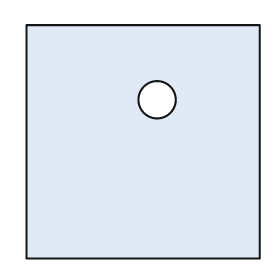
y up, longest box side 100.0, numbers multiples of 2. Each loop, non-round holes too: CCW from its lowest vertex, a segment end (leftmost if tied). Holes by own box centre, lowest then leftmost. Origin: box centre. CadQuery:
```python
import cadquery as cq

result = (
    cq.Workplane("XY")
    .moveTo(-50.0, -50.0)
    .lineTo(50.0, -50.0)
    .lineTo(50.0, 50.0)
    .lineTo(-50.0, 50.0)
    .close()
    .moveTo(6.0, 18.0)
    .circle(8.0)
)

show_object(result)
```